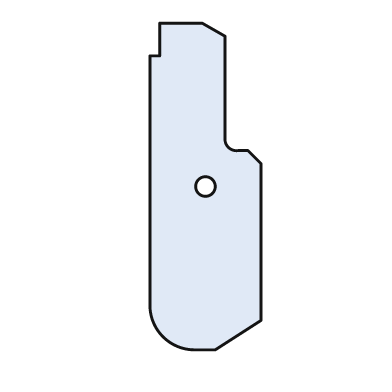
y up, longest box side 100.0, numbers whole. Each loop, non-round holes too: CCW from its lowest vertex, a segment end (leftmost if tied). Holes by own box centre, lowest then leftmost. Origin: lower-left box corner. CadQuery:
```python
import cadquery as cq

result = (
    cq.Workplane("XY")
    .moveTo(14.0, 0.0)
    .lineTo(20.0, 0.0)
    .lineTo(34.0, 9.0)
    .lineTo(34.0, 57.0)
    .lineTo(30.0, 61.0)
    .lineTo(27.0, 61.0)
    .threePointArc((24.0, 62.0), (23.0, 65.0))
    .lineTo(23.0, 96.0)
    .lineTo(16.0, 100.0)
    .lineTo(3.0, 100.0)
    .lineTo(3.0, 90.0)
    .lineTo(0.0, 90.0)
    .lineTo(0.0, 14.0)
    .threePointArc((4.0, 4.0), (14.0, 0.0))
    .close()
    .moveTo(17.0, 50.0)
    .circle(3.0)
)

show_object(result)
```